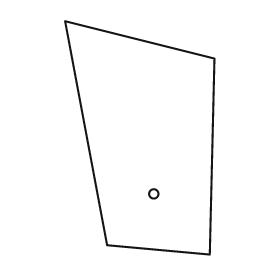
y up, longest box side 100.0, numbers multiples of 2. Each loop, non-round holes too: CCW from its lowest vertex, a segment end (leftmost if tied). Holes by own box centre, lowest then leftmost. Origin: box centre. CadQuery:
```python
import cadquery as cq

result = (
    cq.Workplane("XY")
    .moveTo(30.0, -50.0)
    .lineTo(32.0, 34.0)
    .lineTo(-32.0, 50.0)
    .lineTo(-14.0, -46.0)
    .close()
    .moveTo(6.0, -24.0)
    .circle(2.0)
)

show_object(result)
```